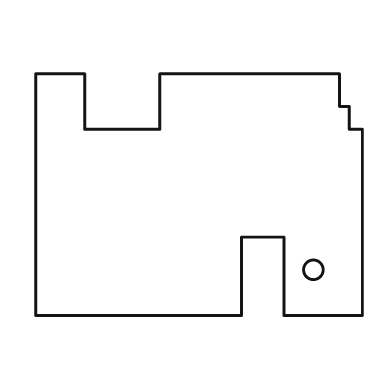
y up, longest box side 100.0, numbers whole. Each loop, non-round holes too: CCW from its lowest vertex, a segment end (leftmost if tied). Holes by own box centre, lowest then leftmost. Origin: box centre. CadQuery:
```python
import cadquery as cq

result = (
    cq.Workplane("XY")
    .moveTo(-50.0, -37.0)
    .lineTo(13.0, -37.0)
    .lineTo(13.0, -13.0)
    .lineTo(26.0, -13.0)
    .lineTo(26.0, -37.0)
    .lineTo(50.0, -37.0)
    .lineTo(50.0, 20.0)
    .lineTo(46.0, 20.0)
    .lineTo(46.0, 27.0)
    .lineTo(43.0, 27.0)
    .lineTo(43.0, 37.0)
    .lineTo(-12.0, 37.0)
    .lineTo(-12.0, 20.0)
    .lineTo(-35.0, 20.0)
    .lineTo(-35.0, 37.0)
    .lineTo(-50.0, 37.0)
    .close()
    .moveTo(35.0, -23.0)
    .circle(3.0)
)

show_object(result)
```